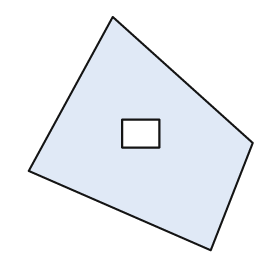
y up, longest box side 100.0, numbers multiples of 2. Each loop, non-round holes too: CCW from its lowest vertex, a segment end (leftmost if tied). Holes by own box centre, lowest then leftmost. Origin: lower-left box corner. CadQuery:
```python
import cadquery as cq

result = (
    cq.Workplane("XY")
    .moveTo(78.0, 0.0)
    .lineTo(96.0, 46.0)
    .lineTo(36.0, 100.0)
    .lineTo(0.0, 34.0)
    .close()
    .moveTo(40.0, 44.0)
    .lineTo(56.0, 44.0)
    .lineTo(56.0, 56.0)
    .lineTo(40.0, 56.0)
    .close()
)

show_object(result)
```